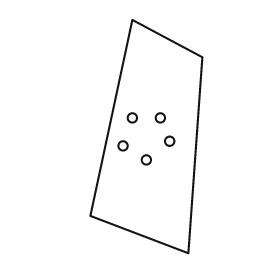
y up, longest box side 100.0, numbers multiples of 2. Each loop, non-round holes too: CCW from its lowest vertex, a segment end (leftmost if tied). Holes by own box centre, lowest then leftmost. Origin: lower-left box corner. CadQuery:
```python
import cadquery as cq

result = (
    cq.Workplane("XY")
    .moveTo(42.0, 0.0)
    .lineTo(48.0, 84.0)
    .lineTo(18.0, 100.0)
    .lineTo(0.0, 16.0)
    .close()
    .moveTo(24.0, 40.0)
    .circle(2.0)
    .moveTo(14.0, 46.0)
    .circle(2.0)
    .moveTo(34.0, 48.0)
    .circle(2.0)
    .moveTo(18.0, 58.0)
    .circle(2.0)
    .moveTo(30.0, 58.0)
    .circle(2.0)
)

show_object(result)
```